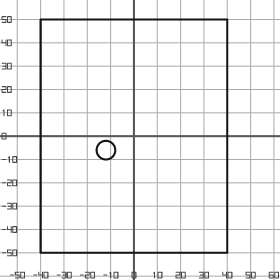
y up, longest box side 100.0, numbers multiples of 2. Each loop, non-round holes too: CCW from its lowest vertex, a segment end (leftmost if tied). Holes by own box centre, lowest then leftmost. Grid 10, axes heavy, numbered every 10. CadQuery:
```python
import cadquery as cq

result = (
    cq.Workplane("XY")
    .moveTo(-40.0, -50.0)
    .lineTo(40.0, -50.0)
    .lineTo(40.0, 50.0)
    .lineTo(-40.0, 50.0)
    .close()
    .moveTo(-12.0, -6.0)
    .circle(4.0)
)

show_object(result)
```